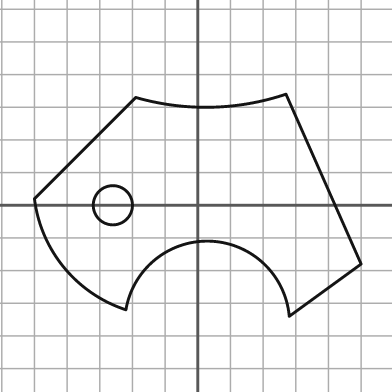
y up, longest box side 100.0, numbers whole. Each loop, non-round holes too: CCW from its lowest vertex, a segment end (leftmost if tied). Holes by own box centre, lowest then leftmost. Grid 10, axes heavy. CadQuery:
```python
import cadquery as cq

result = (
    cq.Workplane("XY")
    .moveTo(28.0, -34.0)
    .lineTo(50.0, -18.0)
    .lineTo(27.0, 34.0)
    .threePointArc((4.0, 30.0), (-19.0, 33.0))
    .lineTo(-50.0, 2.0)
    .threePointArc((-41.0, -19.0), (-22.0, -32.0))
    .threePointArc((4.0, -11.0), (28.0, -34.0))
    .close()
    .moveTo(-26.0, 0.0)
    .circle(6.0)
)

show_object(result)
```